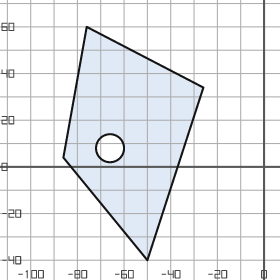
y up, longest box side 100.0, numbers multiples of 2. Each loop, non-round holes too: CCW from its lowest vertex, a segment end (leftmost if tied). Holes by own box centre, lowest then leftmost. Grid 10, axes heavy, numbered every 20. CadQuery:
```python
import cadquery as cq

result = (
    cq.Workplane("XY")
    .moveTo(-50.0, -40.0)
    .lineTo(-26.0, 34.0)
    .lineTo(-76.0, 60.0)
    .lineTo(-86.0, 4.0)
    .close()
    .moveTo(-66.0, 8.0)
    .circle(6.0)
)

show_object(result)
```